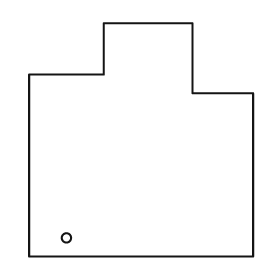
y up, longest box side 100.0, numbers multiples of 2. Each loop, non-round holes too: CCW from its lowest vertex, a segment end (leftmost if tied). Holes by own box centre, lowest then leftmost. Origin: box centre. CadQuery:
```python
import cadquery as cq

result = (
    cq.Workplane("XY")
    .moveTo(-48.0, -50.0)
    .lineTo(48.0, -50.0)
    .lineTo(48.0, 20.0)
    .lineTo(22.0, 20.0)
    .lineTo(22.0, 50.0)
    .lineTo(-16.0, 50.0)
    .lineTo(-16.0, 28.0)
    .lineTo(-48.0, 28.0)
    .close()
    .moveTo(-32.0, -42.0)
    .circle(2.0)
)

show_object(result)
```